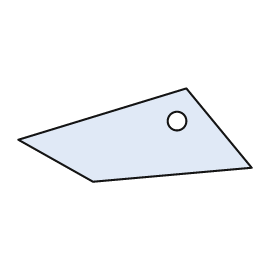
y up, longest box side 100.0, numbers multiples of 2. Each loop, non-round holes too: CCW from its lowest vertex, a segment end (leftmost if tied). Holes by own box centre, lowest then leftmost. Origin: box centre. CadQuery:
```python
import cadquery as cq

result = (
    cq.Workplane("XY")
    .moveTo(-18.0, -20.0)
    .lineTo(50.0, -14.0)
    .lineTo(22.0, 20.0)
    .lineTo(-50.0, -2.0)
    .close()
    .moveTo(18.0, 6.0)
    .circle(4.0)
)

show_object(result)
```